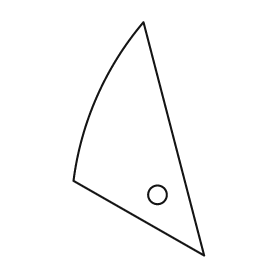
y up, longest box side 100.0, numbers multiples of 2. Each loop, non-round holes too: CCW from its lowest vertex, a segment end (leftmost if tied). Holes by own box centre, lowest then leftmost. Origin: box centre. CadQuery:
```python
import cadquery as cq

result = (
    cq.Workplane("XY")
    .moveTo(28.0, -50.0)
    .lineTo(2.0, 50.0)
    .threePointArc((-18.0, 18.0), (-28.0, -18.0))
    .close()
    .moveTo(8.0, -24.0)
    .circle(4.0)
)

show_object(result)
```